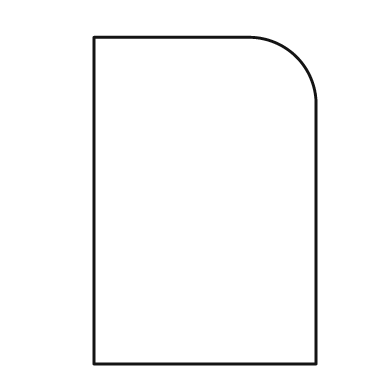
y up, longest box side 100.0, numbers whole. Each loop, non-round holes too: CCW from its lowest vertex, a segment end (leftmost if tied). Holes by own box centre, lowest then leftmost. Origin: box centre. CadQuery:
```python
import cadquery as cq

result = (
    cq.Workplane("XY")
    .moveTo(-34.0, -50.0)
    .lineTo(34.0, -50.0)
    .lineTo(34.0, 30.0)
    .threePointArc((28.0, 44.0), (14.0, 50.0))
    .lineTo(-34.0, 50.0)
    .close()
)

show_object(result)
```